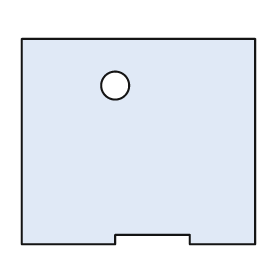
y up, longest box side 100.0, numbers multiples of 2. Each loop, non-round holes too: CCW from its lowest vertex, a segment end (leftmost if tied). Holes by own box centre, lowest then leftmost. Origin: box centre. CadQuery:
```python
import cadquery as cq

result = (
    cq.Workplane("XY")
    .moveTo(-50.0, -44.0)
    .lineTo(-10.0, -44.0)
    .lineTo(-10.0, -40.0)
    .lineTo(22.0, -40.0)
    .lineTo(22.0, -44.0)
    .lineTo(50.0, -44.0)
    .lineTo(50.0, 44.0)
    .lineTo(-50.0, 44.0)
    .close()
    .moveTo(-10.0, 24.0)
    .circle(6.0)
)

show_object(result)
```